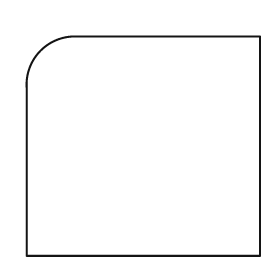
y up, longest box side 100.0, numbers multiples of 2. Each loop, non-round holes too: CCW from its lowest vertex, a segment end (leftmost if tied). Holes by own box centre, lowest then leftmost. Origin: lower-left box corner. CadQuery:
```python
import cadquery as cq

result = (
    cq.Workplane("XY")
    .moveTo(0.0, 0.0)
    .lineTo(100.0, 0.0)
    .lineTo(100.0, 94.0)
    .lineTo(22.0, 94.0)
    .threePointArc((6.0, 88.0), (0.0, 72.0))
    .close()
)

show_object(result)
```